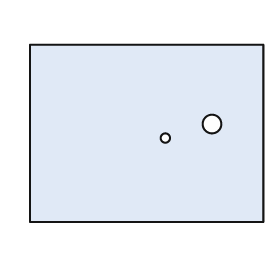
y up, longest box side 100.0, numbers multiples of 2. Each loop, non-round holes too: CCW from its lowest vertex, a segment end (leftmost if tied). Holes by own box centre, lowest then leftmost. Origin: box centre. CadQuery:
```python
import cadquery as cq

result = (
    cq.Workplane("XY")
    .moveTo(-50.0, -38.0)
    .lineTo(50.0, -38.0)
    .lineTo(50.0, 38.0)
    .lineTo(-50.0, 38.0)
    .close()
    .moveTo(8.0, -2.0)
    .circle(2.0)
    .moveTo(28.0, 4.0)
    .circle(4.0)
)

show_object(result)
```